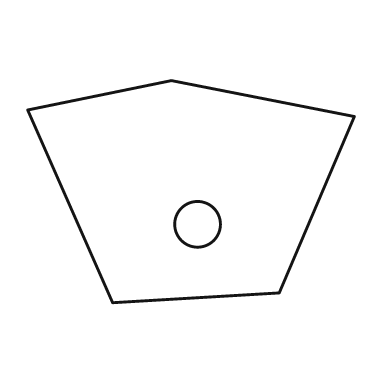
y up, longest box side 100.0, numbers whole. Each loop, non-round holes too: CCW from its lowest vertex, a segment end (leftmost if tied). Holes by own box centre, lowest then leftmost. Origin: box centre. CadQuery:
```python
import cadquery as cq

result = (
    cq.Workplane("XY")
    .moveTo(-24.0, -34.0)
    .lineTo(27.0, -31.0)
    .lineTo(50.0, 23.0)
    .lineTo(-6.0, 34.0)
    .lineTo(-50.0, 25.0)
    .close()
    .moveTo(2.0, -10.0)
    .circle(7.0)
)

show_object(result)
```